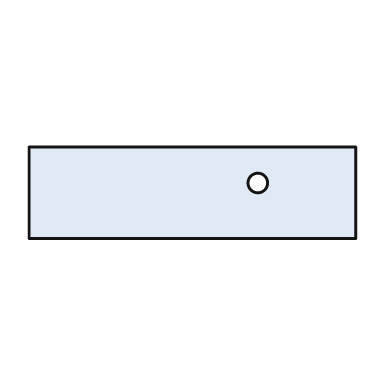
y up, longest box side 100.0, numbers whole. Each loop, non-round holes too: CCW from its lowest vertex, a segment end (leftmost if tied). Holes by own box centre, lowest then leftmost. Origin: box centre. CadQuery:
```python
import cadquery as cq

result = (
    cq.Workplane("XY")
    .moveTo(-50.0, -14.0)
    .lineTo(50.0, -14.0)
    .lineTo(50.0, 14.0)
    .lineTo(-50.0, 14.0)
    .close()
    .moveTo(20.0, 3.0)
    .circle(3.0)
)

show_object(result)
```